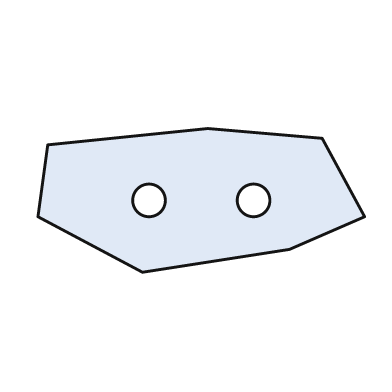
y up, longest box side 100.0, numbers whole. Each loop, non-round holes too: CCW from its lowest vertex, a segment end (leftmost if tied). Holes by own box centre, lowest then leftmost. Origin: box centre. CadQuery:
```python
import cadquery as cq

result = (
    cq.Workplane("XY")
    .moveTo(-18.0, -22.0)
    .lineTo(27.0, -15.0)
    .lineTo(50.0, -5.0)
    .lineTo(37.0, 19.0)
    .lineTo(2.0, 22.0)
    .lineTo(-47.0, 17.0)
    .lineTo(-50.0, -5.0)
    .close()
    .moveTo(-16.0, 0.0)
    .circle(5.0)
    .moveTo(16.0, 0.0)
    .circle(5.0)
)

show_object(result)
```